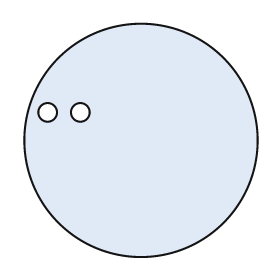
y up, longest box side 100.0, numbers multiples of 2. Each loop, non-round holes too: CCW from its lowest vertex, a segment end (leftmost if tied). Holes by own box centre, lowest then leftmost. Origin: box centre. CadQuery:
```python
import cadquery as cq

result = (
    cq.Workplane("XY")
    .moveTo(0.0, 0.0)
    .circle(50.0)
    .moveTo(-40.0, 12.0)
    .circle(4.0)
    .moveTo(-26.0, 12.0)
    .circle(4.0)
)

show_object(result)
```